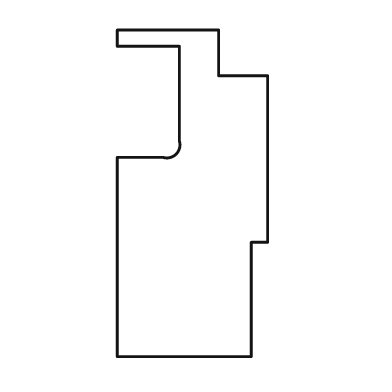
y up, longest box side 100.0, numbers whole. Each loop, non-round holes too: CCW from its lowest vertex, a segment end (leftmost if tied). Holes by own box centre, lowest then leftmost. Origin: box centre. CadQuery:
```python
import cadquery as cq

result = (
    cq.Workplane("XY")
    .moveTo(-23.0, -50.0)
    .lineTo(18.0, -50.0)
    .lineTo(18.0, -15.0)
    .lineTo(23.0, -15.0)
    .lineTo(23.0, 36.0)
    .lineTo(8.0, 36.0)
    .lineTo(8.0, 50.0)
    .lineTo(-23.0, 50.0)
    .lineTo(-23.0, 45.0)
    .lineTo(-4.0, 45.0)
    .lineTo(-4.0, 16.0)
    .threePointArc((-5.0, 12.0), (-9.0, 11.0))
    .lineTo(-23.0, 11.0)
    .close()
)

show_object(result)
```